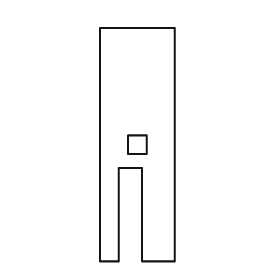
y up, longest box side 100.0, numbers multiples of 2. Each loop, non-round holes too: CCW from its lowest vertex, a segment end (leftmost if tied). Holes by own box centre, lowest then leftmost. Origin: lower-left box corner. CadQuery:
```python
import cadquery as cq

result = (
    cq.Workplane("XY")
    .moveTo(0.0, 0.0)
    .lineTo(8.0, 0.0)
    .lineTo(8.0, 40.0)
    .lineTo(18.0, 40.0)
    .lineTo(18.0, 0.0)
    .lineTo(32.0, 0.0)
    .lineTo(32.0, 100.0)
    .lineTo(0.0, 100.0)
    .close()
    .moveTo(12.0, 46.0)
    .lineTo(20.0, 46.0)
    .lineTo(20.0, 54.0)
    .lineTo(12.0, 54.0)
    .close()
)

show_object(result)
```